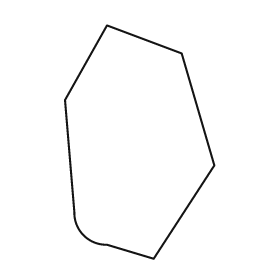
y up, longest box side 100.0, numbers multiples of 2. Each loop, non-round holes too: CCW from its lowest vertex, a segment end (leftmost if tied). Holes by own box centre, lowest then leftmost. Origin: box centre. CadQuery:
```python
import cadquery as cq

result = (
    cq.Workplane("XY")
    .moveTo(6.0, -50.0)
    .lineTo(32.0, -10.0)
    .lineTo(18.0, 38.0)
    .lineTo(-14.0, 50.0)
    .lineTo(-32.0, 18.0)
    .lineTo(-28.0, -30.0)
    .threePointArc((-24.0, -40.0), (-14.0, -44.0))
    .close()
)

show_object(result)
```